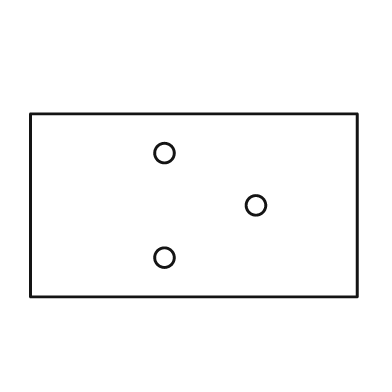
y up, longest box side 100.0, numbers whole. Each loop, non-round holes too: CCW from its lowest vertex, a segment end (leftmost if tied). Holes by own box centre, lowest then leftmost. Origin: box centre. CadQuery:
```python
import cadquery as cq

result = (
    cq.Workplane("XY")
    .moveTo(-50.0, -28.0)
    .lineTo(50.0, -28.0)
    .lineTo(50.0, 28.0)
    .lineTo(-50.0, 28.0)
    .close()
    .moveTo(-9.0, -16.0)
    .circle(3.0)
    .moveTo(19.0, 0.0)
    .circle(3.0)
    .moveTo(-9.0, 16.0)
    .circle(3.0)
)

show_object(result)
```